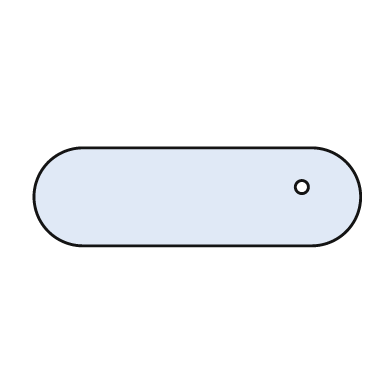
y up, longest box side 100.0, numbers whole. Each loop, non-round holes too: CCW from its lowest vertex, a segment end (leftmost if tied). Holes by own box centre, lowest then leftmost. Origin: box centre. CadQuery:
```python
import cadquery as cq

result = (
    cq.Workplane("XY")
    .moveTo(-35.0, -15.0)
    .lineTo(35.0, -15.0)
    .threePointArc((50.0, 0.0), (35.0, 15.0))
    .lineTo(-35.0, 15.0)
    .threePointArc((-50.0, 0.0), (-35.0, -15.0))
    .close()
    .moveTo(32.0, 3.0)
    .circle(2.0)
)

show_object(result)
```